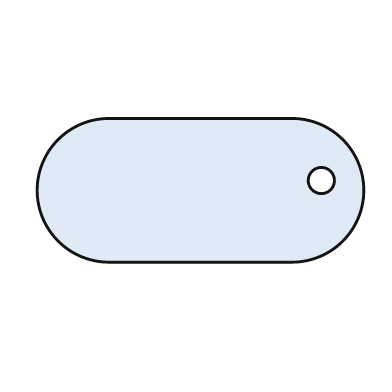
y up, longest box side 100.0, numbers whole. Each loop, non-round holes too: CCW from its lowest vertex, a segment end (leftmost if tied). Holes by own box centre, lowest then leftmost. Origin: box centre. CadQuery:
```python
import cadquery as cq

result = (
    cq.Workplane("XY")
    .moveTo(-28.0, -22.0)
    .lineTo(28.0, -22.0)
    .threePointArc((50.0, 0.0), (28.0, 22.0))
    .lineTo(-28.0, 22.0)
    .threePointArc((-50.0, 0.0), (-28.0, -22.0))
    .close()
    .moveTo(37.0, 3.0)
    .circle(4.0)
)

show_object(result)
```